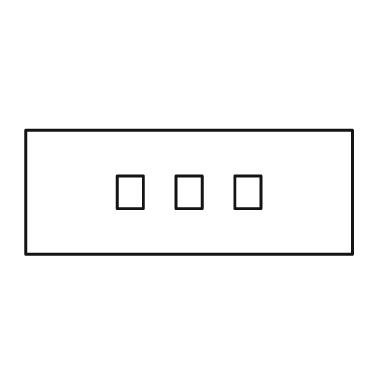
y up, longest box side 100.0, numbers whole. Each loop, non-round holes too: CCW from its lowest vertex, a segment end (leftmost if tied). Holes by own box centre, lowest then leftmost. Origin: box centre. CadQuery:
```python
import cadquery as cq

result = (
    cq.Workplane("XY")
    .moveTo(-50.0, -19.0)
    .lineTo(50.0, -19.0)
    .lineTo(50.0, 19.0)
    .lineTo(-50.0, 19.0)
    .close()
    .moveTo(-22.0, -5.0)
    .lineTo(-14.0, -5.0)
    .lineTo(-14.0, 5.0)
    .lineTo(-22.0, 5.0)
    .close()
    .moveTo(-4.0, -5.0)
    .lineTo(4.0, -5.0)
    .lineTo(4.0, 5.0)
    .lineTo(-4.0, 5.0)
    .close()
    .moveTo(14.0, -5.0)
    .lineTo(22.0, -5.0)
    .lineTo(22.0, 5.0)
    .lineTo(14.0, 5.0)
    .close()
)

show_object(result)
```